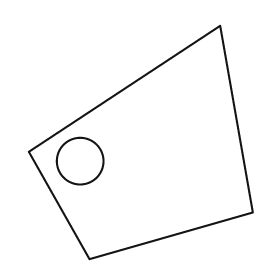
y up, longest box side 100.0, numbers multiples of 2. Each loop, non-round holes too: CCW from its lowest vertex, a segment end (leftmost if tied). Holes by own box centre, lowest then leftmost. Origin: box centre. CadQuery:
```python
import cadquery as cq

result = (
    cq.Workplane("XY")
    .moveTo(-22.0, -50.0)
    .lineTo(48.0, -30.0)
    .lineTo(34.0, 50.0)
    .lineTo(-48.0, -4.0)
    .close()
    .moveTo(-26.0, -8.0)
    .circle(10.0)
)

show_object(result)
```